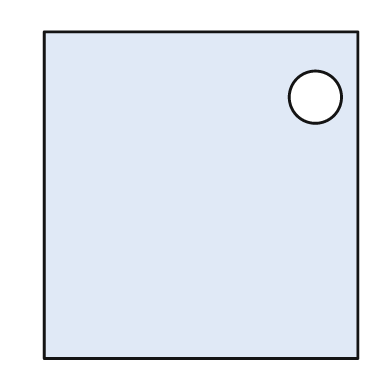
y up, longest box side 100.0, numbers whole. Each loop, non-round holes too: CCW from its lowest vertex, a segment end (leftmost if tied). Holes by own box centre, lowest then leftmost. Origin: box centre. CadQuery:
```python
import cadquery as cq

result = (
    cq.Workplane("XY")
    .moveTo(-48.0, -50.0)
    .lineTo(48.0, -50.0)
    .lineTo(48.0, 50.0)
    .lineTo(-48.0, 50.0)
    .close()
    .moveTo(35.0, 30.0)
    .circle(8.0)
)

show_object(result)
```